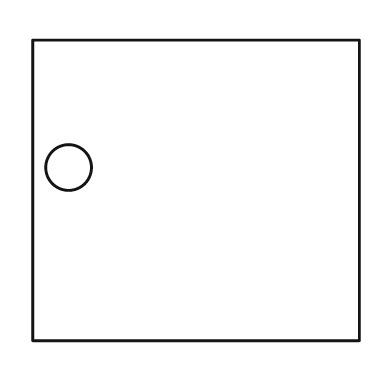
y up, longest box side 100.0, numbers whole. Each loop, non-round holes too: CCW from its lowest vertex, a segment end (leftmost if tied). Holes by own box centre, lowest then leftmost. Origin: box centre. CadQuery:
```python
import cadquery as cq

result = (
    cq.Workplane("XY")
    .moveTo(-50.0, -46.0)
    .lineTo(50.0, -46.0)
    .lineTo(50.0, 46.0)
    .lineTo(-50.0, 46.0)
    .close()
    .moveTo(-39.0, 7.0)
    .circle(7.0)
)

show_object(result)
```